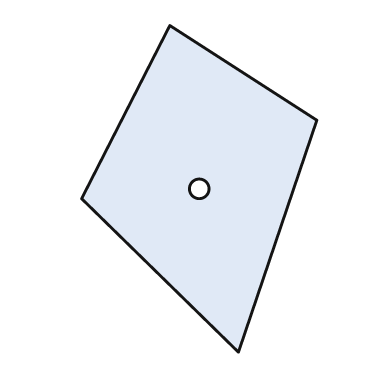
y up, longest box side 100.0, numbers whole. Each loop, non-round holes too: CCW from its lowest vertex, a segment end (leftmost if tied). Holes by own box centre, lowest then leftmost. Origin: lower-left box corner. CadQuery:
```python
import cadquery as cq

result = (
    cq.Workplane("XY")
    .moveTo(48.0, 0.0)
    .lineTo(72.0, 71.0)
    .lineTo(27.0, 100.0)
    .lineTo(0.0, 47.0)
    .close()
    .moveTo(36.0, 50.0)
    .circle(3.0)
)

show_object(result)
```